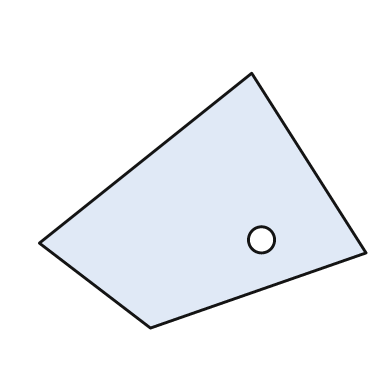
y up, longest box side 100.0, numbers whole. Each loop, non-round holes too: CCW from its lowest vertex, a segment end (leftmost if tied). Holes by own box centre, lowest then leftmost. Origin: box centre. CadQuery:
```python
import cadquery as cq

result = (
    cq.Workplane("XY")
    .moveTo(-16.0, -39.0)
    .lineTo(50.0, -16.0)
    .lineTo(15.0, 39.0)
    .lineTo(-50.0, -13.0)
    .close()
    .moveTo(18.0, -12.0)
    .circle(4.0)
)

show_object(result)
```